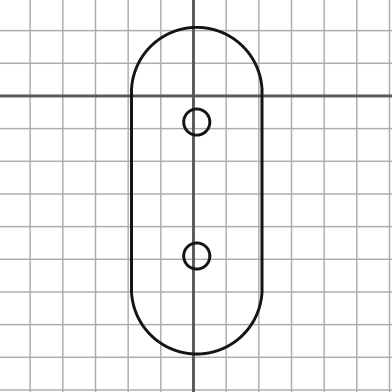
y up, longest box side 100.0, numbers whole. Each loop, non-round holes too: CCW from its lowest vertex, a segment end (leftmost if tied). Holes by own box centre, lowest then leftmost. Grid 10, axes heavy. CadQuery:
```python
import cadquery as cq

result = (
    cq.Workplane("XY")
    .moveTo(-19.0, -59.0)
    .threePointArc((1.0, -79.0), (21.0, -59.0))
    .lineTo(21.0, 1.0)
    .threePointArc((1.0, 21.0), (-19.0, 1.0))
    .close()
    .moveTo(1.0, -49.0)
    .circle(4.0)
    .moveTo(1.0, -8.0)
    .circle(4.0)
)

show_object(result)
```